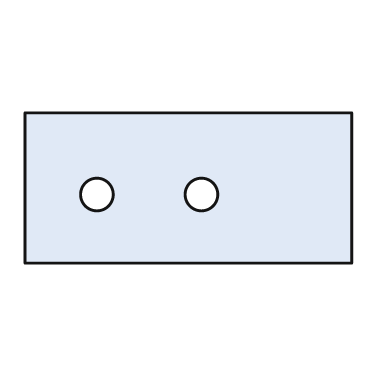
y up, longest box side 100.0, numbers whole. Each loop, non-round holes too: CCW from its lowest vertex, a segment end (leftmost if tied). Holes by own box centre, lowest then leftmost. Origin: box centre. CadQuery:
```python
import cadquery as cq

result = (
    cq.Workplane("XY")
    .moveTo(-50.0, -23.0)
    .lineTo(50.0, -23.0)
    .lineTo(50.0, 23.0)
    .lineTo(-50.0, 23.0)
    .close()
    .moveTo(-28.0, -2.0)
    .circle(5.0)
    .moveTo(4.0, -2.0)
    .circle(5.0)
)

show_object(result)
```